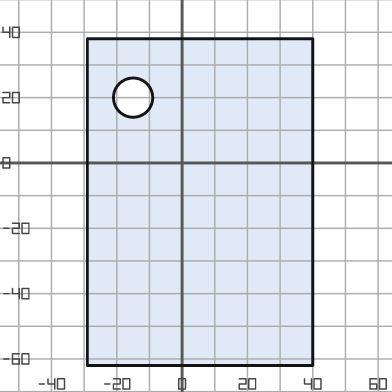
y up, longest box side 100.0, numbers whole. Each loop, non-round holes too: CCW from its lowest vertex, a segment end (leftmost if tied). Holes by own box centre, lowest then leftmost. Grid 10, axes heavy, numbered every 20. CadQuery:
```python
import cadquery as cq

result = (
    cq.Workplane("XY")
    .moveTo(-29.0, -62.0)
    .lineTo(40.0, -62.0)
    .lineTo(40.0, 38.0)
    .lineTo(-29.0, 38.0)
    .close()
    .moveTo(-15.0, 20.0)
    .circle(6.0)
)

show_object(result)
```